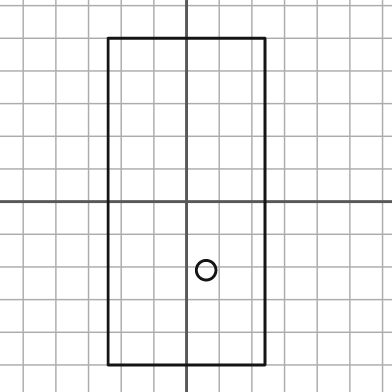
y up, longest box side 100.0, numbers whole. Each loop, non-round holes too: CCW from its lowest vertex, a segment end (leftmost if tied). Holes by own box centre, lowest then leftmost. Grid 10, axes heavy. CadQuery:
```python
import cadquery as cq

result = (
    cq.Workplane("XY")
    .moveTo(-24.0, -50.0)
    .lineTo(24.0, -50.0)
    .lineTo(24.0, 50.0)
    .lineTo(-24.0, 50.0)
    .close()
    .moveTo(6.0, -21.0)
    .circle(3.0)
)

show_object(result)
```